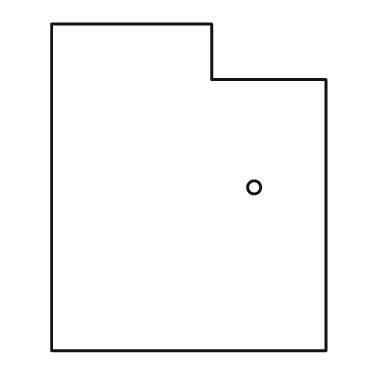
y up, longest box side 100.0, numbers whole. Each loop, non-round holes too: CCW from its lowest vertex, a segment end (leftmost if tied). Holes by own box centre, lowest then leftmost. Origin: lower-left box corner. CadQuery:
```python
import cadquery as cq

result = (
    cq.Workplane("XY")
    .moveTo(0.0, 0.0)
    .lineTo(84.0, 0.0)
    .lineTo(84.0, 83.0)
    .lineTo(49.0, 83.0)
    .lineTo(49.0, 100.0)
    .lineTo(0.0, 100.0)
    .close()
    .moveTo(62.0, 50.0)
    .circle(2.0)
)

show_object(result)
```